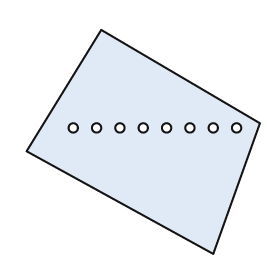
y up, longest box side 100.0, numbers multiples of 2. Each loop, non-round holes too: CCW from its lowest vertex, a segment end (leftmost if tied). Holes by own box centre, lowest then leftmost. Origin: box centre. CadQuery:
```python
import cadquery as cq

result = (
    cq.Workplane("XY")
    .moveTo(30.0, -48.0)
    .lineTo(50.0, 8.0)
    .lineTo(-18.0, 48.0)
    .lineTo(-50.0, -4.0)
    .close()
    .moveTo(-30.0, 6.0)
    .circle(2.0)
    .moveTo(-20.0, 6.0)
    .circle(2.0)
    .moveTo(-10.0, 6.0)
    .circle(2.0)
    .moveTo(0.0, 6.0)
    .circle(2.0)
    .moveTo(10.0, 6.0)
    .circle(2.0)
    .moveTo(20.0, 6.0)
    .circle(2.0)
    .moveTo(30.0, 6.0)
    .circle(2.0)
    .moveTo(40.0, 6.0)
    .circle(2.0)
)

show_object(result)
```